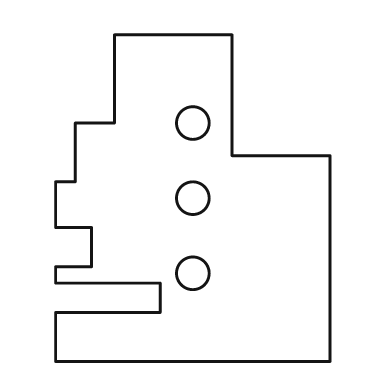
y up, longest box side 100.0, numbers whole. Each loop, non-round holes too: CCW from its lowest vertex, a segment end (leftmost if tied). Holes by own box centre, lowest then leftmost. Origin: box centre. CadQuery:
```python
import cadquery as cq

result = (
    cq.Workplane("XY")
    .moveTo(-42.0, -50.0)
    .lineTo(42.0, -50.0)
    .lineTo(42.0, 13.0)
    .lineTo(12.0, 13.0)
    .lineTo(12.0, 50.0)
    .lineTo(-24.0, 50.0)
    .lineTo(-24.0, 23.0)
    .lineTo(-36.0, 23.0)
    .lineTo(-36.0, 5.0)
    .lineTo(-42.0, 5.0)
    .lineTo(-42.0, -9.0)
    .lineTo(-31.0, -9.0)
    .lineTo(-31.0, -21.0)
    .lineTo(-42.0, -21.0)
    .lineTo(-42.0, -26.0)
    .lineTo(-10.0, -26.0)
    .lineTo(-10.0, -35.0)
    .lineTo(-42.0, -35.0)
    .close()
    .moveTo(0.0, -23.0)
    .circle(5.0)
    .moveTo(0.0, 0.0)
    .circle(5.0)
    .moveTo(0.0, 23.0)
    .circle(5.0)
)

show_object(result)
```